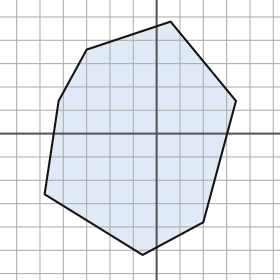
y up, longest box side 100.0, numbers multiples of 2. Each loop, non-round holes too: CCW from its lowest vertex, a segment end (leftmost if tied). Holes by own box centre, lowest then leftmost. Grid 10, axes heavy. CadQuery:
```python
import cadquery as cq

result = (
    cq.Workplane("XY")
    .moveTo(-6.0, -52.0)
    .lineTo(20.0, -38.0)
    .lineTo(34.0, 14.0)
    .lineTo(6.0, 48.0)
    .lineTo(-30.0, 36.0)
    .lineTo(-42.0, 14.0)
    .lineTo(-48.0, -26.0)
    .close()
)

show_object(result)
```